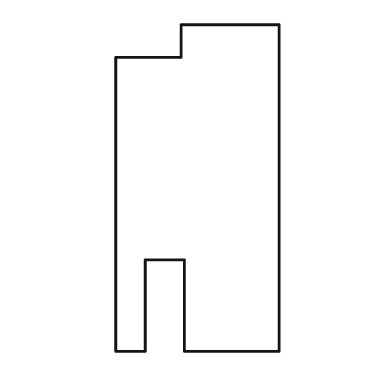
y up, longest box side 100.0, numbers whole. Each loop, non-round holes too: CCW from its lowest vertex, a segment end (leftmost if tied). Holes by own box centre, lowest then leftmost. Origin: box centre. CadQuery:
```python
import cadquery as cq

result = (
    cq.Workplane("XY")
    .moveTo(-25.0, -50.0)
    .lineTo(-16.0, -50.0)
    .lineTo(-16.0, -22.0)
    .lineTo(-4.0, -22.0)
    .lineTo(-4.0, -50.0)
    .lineTo(25.0, -50.0)
    .lineTo(25.0, 50.0)
    .lineTo(-5.0, 50.0)
    .lineTo(-5.0, 40.0)
    .lineTo(-25.0, 40.0)
    .close()
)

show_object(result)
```